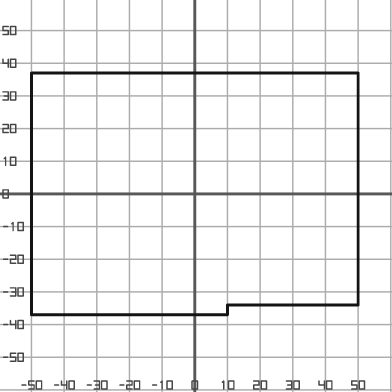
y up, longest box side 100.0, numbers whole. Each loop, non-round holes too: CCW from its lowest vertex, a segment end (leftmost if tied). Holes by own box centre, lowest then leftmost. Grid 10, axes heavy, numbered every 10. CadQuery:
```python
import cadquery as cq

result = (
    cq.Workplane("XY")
    .moveTo(-50.0, -37.0)
    .lineTo(10.0, -37.0)
    .lineTo(10.0, -34.0)
    .lineTo(50.0, -34.0)
    .lineTo(50.0, 37.0)
    .lineTo(-50.0, 37.0)
    .close()
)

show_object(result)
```